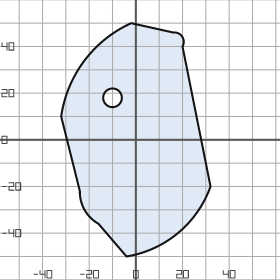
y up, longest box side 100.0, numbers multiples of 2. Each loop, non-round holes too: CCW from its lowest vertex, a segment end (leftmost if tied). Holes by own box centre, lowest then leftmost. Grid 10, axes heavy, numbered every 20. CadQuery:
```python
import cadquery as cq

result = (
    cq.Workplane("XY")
    .moveTo(-4.0, -50.0)
    .threePointArc((18.0, -40.0), (32.0, -20.0))
    .lineTo(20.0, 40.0)
    .threePointArc((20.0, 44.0), (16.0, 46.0))
    .lineTo(-2.0, 50.0)
    .threePointArc((-22.0, 34.0), (-32.0, 10.0))
    .lineTo(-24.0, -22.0)
    .threePointArc((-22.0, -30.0), (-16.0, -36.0))
    .close()
    .moveTo(-10.0, 18.0)
    .circle(4.0)
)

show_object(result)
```